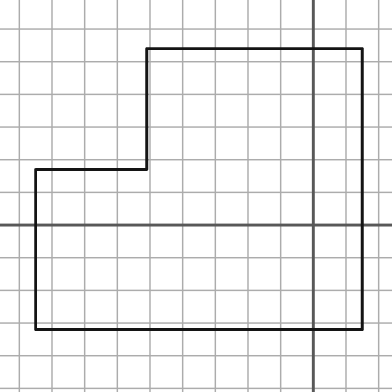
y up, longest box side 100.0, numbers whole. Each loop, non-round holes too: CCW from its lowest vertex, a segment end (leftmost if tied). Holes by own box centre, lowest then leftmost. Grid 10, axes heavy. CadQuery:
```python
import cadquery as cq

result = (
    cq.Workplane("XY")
    .moveTo(-85.0, -32.0)
    .lineTo(15.0, -32.0)
    .lineTo(15.0, 54.0)
    .lineTo(-51.0, 54.0)
    .lineTo(-51.0, 17.0)
    .lineTo(-85.0, 17.0)
    .close()
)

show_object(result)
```